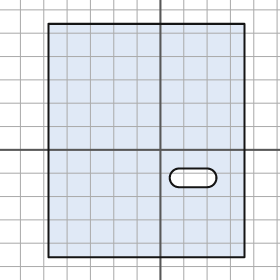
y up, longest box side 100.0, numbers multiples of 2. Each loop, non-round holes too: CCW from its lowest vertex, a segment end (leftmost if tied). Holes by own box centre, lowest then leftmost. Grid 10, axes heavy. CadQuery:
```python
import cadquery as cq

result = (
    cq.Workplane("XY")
    .moveTo(-48.0, -46.0)
    .lineTo(36.0, -46.0)
    .lineTo(36.0, 54.0)
    .lineTo(-48.0, 54.0)
    .close()
    .moveTo(8.0, -16.0)
    .lineTo(20.0, -16.0)
    .threePointArc((24.0, -12.0), (20.0, -8.0))
    .lineTo(8.0, -8.0)
    .threePointArc((4.0, -12.0), (8.0, -16.0))
    .close()
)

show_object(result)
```